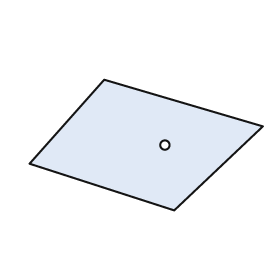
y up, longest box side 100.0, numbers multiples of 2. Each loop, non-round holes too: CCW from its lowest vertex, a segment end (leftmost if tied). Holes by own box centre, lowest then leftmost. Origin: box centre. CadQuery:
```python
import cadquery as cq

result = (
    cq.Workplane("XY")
    .moveTo(12.0, -28.0)
    .lineTo(50.0, 8.0)
    .lineTo(-18.0, 28.0)
    .lineTo(-50.0, -8.0)
    .close()
    .moveTo(8.0, 0.0)
    .circle(2.0)
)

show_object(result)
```